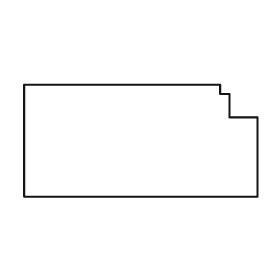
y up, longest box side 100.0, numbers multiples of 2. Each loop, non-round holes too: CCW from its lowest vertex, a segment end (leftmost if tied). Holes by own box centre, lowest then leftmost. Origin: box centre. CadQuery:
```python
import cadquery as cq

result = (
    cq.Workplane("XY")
    .moveTo(-50.0, -24.0)
    .lineTo(50.0, -24.0)
    .lineTo(50.0, 10.0)
    .lineTo(38.0, 10.0)
    .lineTo(38.0, 20.0)
    .lineTo(34.0, 20.0)
    .lineTo(34.0, 24.0)
    .lineTo(-50.0, 24.0)
    .close()
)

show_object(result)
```